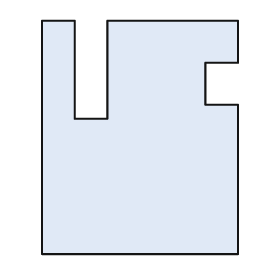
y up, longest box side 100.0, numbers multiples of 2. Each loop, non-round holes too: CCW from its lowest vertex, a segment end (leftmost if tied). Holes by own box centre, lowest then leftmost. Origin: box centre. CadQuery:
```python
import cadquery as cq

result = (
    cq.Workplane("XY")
    .moveTo(-42.0, -50.0)
    .lineTo(42.0, -50.0)
    .lineTo(42.0, 14.0)
    .lineTo(28.0, 14.0)
    .lineTo(28.0, 32.0)
    .lineTo(42.0, 32.0)
    .lineTo(42.0, 50.0)
    .lineTo(-14.0, 50.0)
    .lineTo(-14.0, 8.0)
    .lineTo(-28.0, 8.0)
    .lineTo(-28.0, 50.0)
    .lineTo(-42.0, 50.0)
    .close()
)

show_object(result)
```